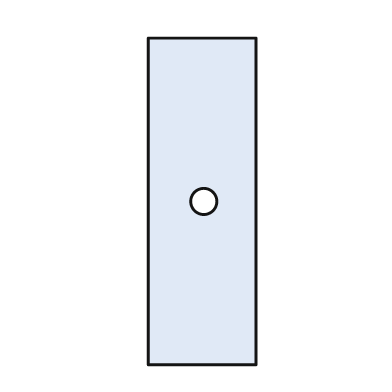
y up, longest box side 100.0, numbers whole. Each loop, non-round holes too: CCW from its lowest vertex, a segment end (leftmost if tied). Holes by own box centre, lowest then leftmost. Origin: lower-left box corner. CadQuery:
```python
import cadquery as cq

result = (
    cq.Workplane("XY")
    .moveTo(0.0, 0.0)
    .lineTo(33.0, 0.0)
    .lineTo(33.0, 100.0)
    .lineTo(0.0, 100.0)
    .close()
    .moveTo(17.0, 50.0)
    .circle(4.0)
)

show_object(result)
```